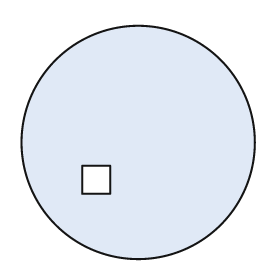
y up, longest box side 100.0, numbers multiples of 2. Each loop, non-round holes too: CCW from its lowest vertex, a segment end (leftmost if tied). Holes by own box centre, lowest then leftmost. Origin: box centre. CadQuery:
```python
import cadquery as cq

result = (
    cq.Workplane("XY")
    .moveTo(0.0, 0.0)
    .circle(50.0)
    .moveTo(-24.0, -22.0)
    .lineTo(-12.0, -22.0)
    .lineTo(-12.0, -10.0)
    .lineTo(-24.0, -10.0)
    .close()
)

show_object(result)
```